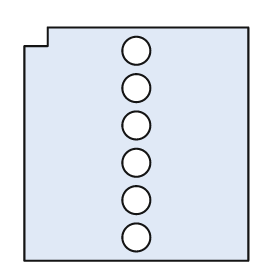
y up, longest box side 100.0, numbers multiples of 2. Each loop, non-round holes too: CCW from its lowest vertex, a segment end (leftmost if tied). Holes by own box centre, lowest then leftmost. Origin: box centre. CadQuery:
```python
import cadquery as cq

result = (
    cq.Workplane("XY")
    .moveTo(-48.0, -50.0)
    .lineTo(48.0, -50.0)
    .lineTo(48.0, 50.0)
    .lineTo(-38.0, 50.0)
    .lineTo(-38.0, 42.0)
    .lineTo(-48.0, 42.0)
    .close()
    .moveTo(0.0, -40.0)
    .circle(6.0)
    .moveTo(0.0, -24.0)
    .circle(6.0)
    .moveTo(0.0, -8.0)
    .circle(6.0)
    .moveTo(0.0, 8.0)
    .circle(6.0)
    .moveTo(0.0, 24.0)
    .circle(6.0)
    .moveTo(0.0, 40.0)
    .circle(6.0)
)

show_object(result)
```